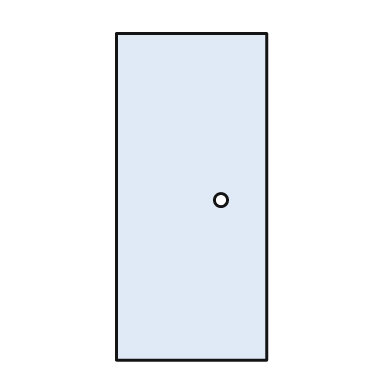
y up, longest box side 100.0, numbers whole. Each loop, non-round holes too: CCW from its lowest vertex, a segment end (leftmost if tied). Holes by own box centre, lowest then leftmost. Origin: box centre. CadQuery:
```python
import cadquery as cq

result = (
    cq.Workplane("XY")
    .moveTo(-23.0, -50.0)
    .lineTo(23.0, -50.0)
    .lineTo(23.0, 50.0)
    .lineTo(-23.0, 50.0)
    .close()
    .moveTo(9.0, -1.0)
    .circle(2.0)
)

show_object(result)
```